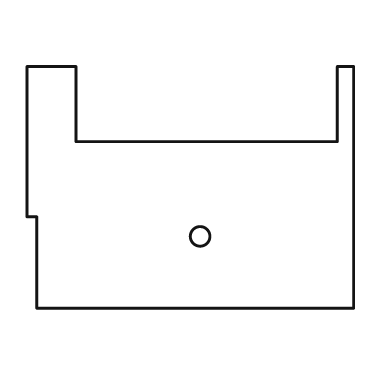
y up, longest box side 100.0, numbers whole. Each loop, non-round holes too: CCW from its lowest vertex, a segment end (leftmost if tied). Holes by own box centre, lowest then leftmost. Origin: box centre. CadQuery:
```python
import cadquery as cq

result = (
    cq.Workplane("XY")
    .moveTo(-47.0, -37.0)
    .lineTo(50.0, -37.0)
    .lineTo(50.0, 37.0)
    .lineTo(45.0, 37.0)
    .lineTo(45.0, 14.0)
    .lineTo(-35.0, 14.0)
    .lineTo(-35.0, 37.0)
    .lineTo(-50.0, 37.0)
    .lineTo(-50.0, -9.0)
    .lineTo(-47.0, -9.0)
    .close()
    .moveTo(3.0, -15.0)
    .circle(3.0)
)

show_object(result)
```